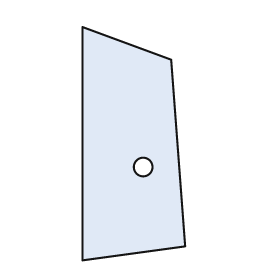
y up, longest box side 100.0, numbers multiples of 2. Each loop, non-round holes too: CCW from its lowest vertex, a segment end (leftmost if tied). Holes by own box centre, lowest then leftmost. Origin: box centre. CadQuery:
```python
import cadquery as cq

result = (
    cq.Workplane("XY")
    .moveTo(-22.0, -50.0)
    .lineTo(22.0, -44.0)
    .lineTo(16.0, 36.0)
    .lineTo(-22.0, 50.0)
    .close()
    .moveTo(4.0, -10.0)
    .circle(4.0)
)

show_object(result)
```